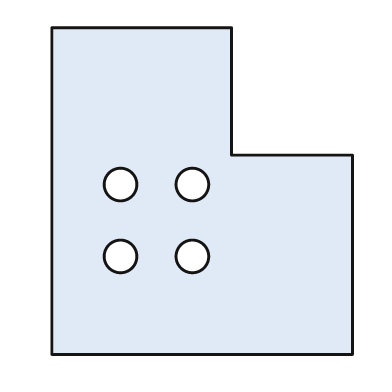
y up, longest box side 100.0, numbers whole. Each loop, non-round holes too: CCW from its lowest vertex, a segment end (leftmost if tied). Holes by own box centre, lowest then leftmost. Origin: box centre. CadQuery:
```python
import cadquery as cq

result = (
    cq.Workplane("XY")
    .moveTo(-46.0, -50.0)
    .lineTo(46.0, -50.0)
    .lineTo(46.0, 11.0)
    .lineTo(9.0, 11.0)
    .lineTo(9.0, 50.0)
    .lineTo(-46.0, 50.0)
    .close()
    .moveTo(-25.0, -20.0)
    .circle(5.0)
    .moveTo(-3.0, -20.0)
    .circle(5.0)
    .moveTo(-25.0, 2.0)
    .circle(5.0)
    .moveTo(-3.0, 2.0)
    .circle(5.0)
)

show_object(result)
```